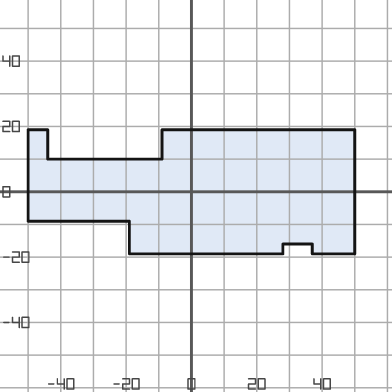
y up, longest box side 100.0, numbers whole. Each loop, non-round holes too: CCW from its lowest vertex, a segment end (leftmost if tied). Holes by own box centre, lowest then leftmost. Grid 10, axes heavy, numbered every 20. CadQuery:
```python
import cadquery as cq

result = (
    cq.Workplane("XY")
    .moveTo(-19.0, -19.0)
    .lineTo(28.0, -19.0)
    .lineTo(28.0, -16.0)
    .lineTo(37.0, -16.0)
    .lineTo(37.0, -19.0)
    .lineTo(50.0, -19.0)
    .lineTo(50.0, 19.0)
    .lineTo(-9.0, 19.0)
    .lineTo(-9.0, 10.0)
    .lineTo(-44.0, 10.0)
    .lineTo(-44.0, 19.0)
    .lineTo(-50.0, 19.0)
    .lineTo(-50.0, -9.0)
    .lineTo(-19.0, -9.0)
    .close()
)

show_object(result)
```